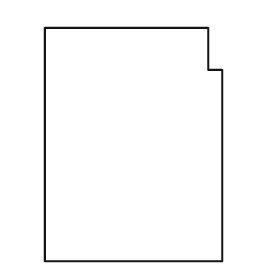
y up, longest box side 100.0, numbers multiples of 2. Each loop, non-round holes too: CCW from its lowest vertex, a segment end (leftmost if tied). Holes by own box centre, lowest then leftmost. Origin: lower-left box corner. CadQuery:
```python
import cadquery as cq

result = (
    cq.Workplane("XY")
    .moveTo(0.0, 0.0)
    .lineTo(76.0, 0.0)
    .lineTo(76.0, 82.0)
    .lineTo(70.0, 82.0)
    .lineTo(70.0, 100.0)
    .lineTo(0.0, 100.0)
    .close()
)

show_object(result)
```